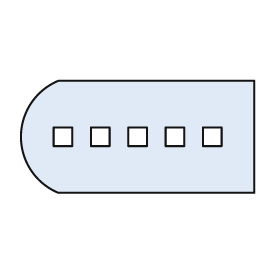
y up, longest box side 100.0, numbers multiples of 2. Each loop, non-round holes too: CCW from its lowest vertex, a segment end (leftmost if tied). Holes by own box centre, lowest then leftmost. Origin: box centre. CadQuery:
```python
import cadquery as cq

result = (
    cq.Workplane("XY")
    .moveTo(-34.0, -24.0)
    .lineTo(50.0, -24.0)
    .lineTo(50.0, 24.0)
    .lineTo(-34.0, 24.0)
    .threePointArc((-50.0, 0.0), (-34.0, -24.0))
    .close()
    .moveTo(-36.0, -4.0)
    .lineTo(-28.0, -4.0)
    .lineTo(-28.0, 4.0)
    .lineTo(-36.0, 4.0)
    .close()
    .moveTo(-20.0, -4.0)
    .lineTo(-12.0, -4.0)
    .lineTo(-12.0, 4.0)
    .lineTo(-20.0, 4.0)
    .close()
    .moveTo(-4.0, -4.0)
    .lineTo(4.0, -4.0)
    .lineTo(4.0, 4.0)
    .lineTo(-4.0, 4.0)
    .close()
    .moveTo(12.0, -4.0)
    .lineTo(20.0, -4.0)
    .lineTo(20.0, 4.0)
    .lineTo(12.0, 4.0)
    .close()
    .moveTo(28.0, -4.0)
    .lineTo(36.0, -4.0)
    .lineTo(36.0, 4.0)
    .lineTo(28.0, 4.0)
    .close()
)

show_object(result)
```